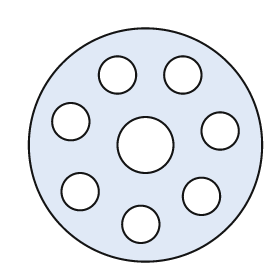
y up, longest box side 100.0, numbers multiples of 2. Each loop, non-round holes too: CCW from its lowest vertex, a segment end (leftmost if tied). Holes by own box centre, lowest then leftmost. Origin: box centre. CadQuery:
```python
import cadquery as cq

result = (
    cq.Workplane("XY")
    .moveTo(0.0, 0.0)
    .circle(50.0)
    .moveTo(-2.0, -34.0)
    .circle(8.0)
    .moveTo(24.0, -22.0)
    .circle(8.0)
    .moveTo(-28.0, -20.0)
    .circle(8.0)
    .moveTo(0.0, 0.0)
    .circle(12.0)
    .moveTo(32.0, 6.0)
    .circle(8.0)
    .moveTo(-32.0, 10.0)
    .circle(8.0)
    .moveTo(-12.0, 30.0)
    .circle(8.0)
    .moveTo(16.0, 30.0)
    .circle(8.0)
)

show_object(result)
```